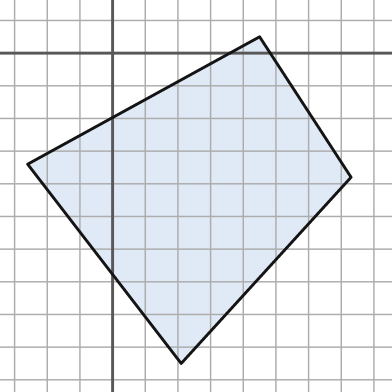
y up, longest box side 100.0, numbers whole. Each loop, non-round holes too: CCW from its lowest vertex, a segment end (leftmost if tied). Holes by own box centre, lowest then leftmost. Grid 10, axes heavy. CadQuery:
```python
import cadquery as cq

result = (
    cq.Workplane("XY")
    .moveTo(21.0, -95.0)
    .lineTo(73.0, -38.0)
    .lineTo(45.0, 5.0)
    .lineTo(-26.0, -34.0)
    .close()
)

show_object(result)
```